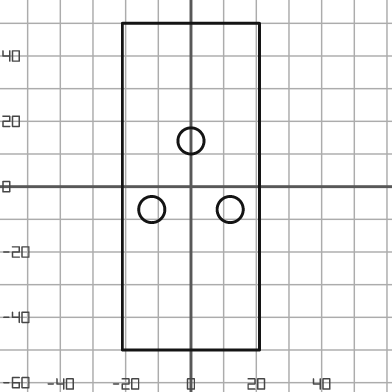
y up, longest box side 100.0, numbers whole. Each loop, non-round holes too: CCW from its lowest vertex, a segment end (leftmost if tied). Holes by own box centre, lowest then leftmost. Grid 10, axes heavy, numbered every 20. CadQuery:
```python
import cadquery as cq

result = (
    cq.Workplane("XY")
    .moveTo(-21.0, -50.0)
    .lineTo(21.0, -50.0)
    .lineTo(21.0, 50.0)
    .lineTo(-21.0, 50.0)
    .close()
    .moveTo(-12.0, -7.0)
    .circle(4.0)
    .moveTo(12.0, -7.0)
    .circle(4.0)
    .moveTo(0.0, 14.0)
    .circle(4.0)
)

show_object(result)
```